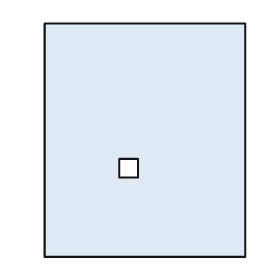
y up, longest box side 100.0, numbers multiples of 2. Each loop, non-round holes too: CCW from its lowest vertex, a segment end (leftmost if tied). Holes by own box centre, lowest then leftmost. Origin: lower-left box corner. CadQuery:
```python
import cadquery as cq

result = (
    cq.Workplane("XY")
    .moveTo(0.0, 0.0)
    .lineTo(86.0, 0.0)
    .lineTo(86.0, 100.0)
    .lineTo(0.0, 100.0)
    .close()
    .moveTo(32.0, 34.0)
    .lineTo(40.0, 34.0)
    .lineTo(40.0, 42.0)
    .lineTo(32.0, 42.0)
    .close()
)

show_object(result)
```